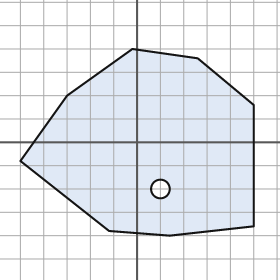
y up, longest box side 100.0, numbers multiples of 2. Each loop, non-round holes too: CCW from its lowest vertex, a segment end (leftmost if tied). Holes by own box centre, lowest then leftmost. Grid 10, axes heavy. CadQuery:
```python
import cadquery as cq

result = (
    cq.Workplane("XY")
    .moveTo(14.0, -40.0)
    .lineTo(50.0, -36.0)
    .lineTo(50.0, 16.0)
    .lineTo(26.0, 36.0)
    .lineTo(-2.0, 40.0)
    .lineTo(-30.0, 20.0)
    .lineTo(-50.0, -8.0)
    .lineTo(-12.0, -38.0)
    .close()
    .moveTo(10.0, -20.0)
    .circle(4.0)
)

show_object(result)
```